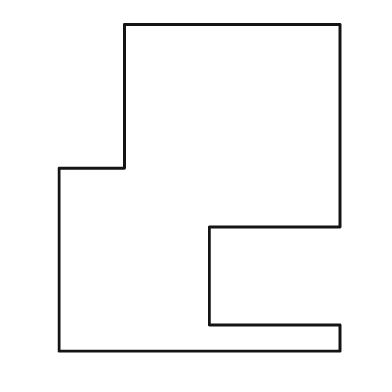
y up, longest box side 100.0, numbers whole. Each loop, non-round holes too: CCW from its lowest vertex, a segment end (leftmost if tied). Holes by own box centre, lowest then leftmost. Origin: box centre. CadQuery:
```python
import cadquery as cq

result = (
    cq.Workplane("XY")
    .moveTo(-43.0, -50.0)
    .lineTo(43.0, -50.0)
    .lineTo(43.0, -42.0)
    .lineTo(3.0, -42.0)
    .lineTo(3.0, -12.0)
    .lineTo(43.0, -12.0)
    .lineTo(43.0, 50.0)
    .lineTo(-23.0, 50.0)
    .lineTo(-23.0, 6.0)
    .lineTo(-43.0, 6.0)
    .close()
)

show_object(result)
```